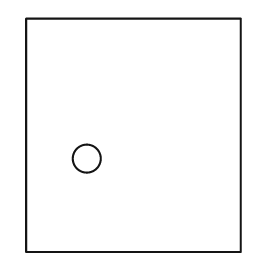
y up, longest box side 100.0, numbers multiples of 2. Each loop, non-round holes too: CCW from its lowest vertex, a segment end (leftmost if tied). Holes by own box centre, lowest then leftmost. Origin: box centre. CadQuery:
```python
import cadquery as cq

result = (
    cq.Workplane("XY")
    .moveTo(-46.0, -50.0)
    .lineTo(46.0, -50.0)
    .lineTo(46.0, 50.0)
    .lineTo(-46.0, 50.0)
    .close()
    .moveTo(-20.0, -10.0)
    .circle(6.0)
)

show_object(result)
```